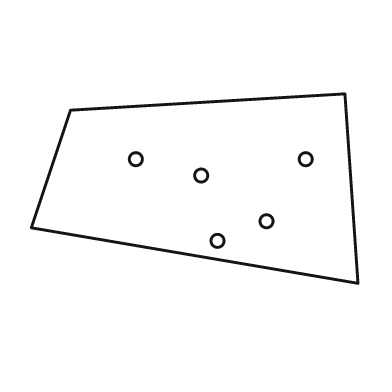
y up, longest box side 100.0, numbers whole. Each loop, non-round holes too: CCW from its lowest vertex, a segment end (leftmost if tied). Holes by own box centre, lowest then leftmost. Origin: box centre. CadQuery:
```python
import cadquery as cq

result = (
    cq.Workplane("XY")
    .moveTo(50.0, -29.0)
    .lineTo(46.0, 29.0)
    .lineTo(-38.0, 24.0)
    .lineTo(-50.0, -12.0)
    .close()
    .moveTo(7.0, -16.0)
    .circle(2.0)
    .moveTo(22.0, -10.0)
    .circle(2.0)
    .moveTo(2.0, 4.0)
    .circle(2.0)
    .moveTo(-18.0, 9.0)
    .circle(2.0)
    .moveTo(34.0, 9.0)
    .circle(2.0)
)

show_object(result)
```